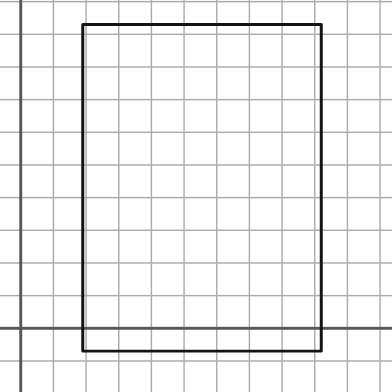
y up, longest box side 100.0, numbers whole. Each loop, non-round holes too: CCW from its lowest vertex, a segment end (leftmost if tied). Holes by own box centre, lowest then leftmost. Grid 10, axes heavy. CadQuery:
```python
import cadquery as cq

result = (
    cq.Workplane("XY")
    .moveTo(19.0, -7.0)
    .lineTo(92.0, -7.0)
    .lineTo(92.0, 93.0)
    .lineTo(19.0, 93.0)
    .close()
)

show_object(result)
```